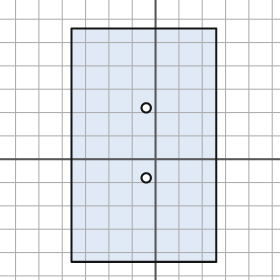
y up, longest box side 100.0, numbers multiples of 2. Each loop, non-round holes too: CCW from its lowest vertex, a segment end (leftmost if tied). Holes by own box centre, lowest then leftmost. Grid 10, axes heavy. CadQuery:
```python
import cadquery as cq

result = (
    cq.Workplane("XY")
    .moveTo(-36.0, -44.0)
    .lineTo(26.0, -44.0)
    .lineTo(26.0, 56.0)
    .lineTo(-36.0, 56.0)
    .close()
    .moveTo(-4.0, -8.0)
    .circle(2.0)
    .moveTo(-4.0, 22.0)
    .circle(2.0)
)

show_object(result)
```